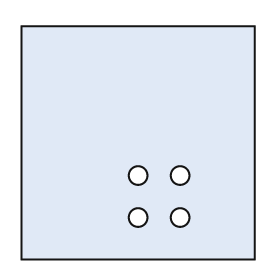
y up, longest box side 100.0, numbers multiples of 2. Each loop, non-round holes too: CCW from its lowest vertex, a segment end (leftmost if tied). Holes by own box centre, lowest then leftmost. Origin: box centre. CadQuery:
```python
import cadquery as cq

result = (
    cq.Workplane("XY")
    .moveTo(-50.0, -50.0)
    .lineTo(50.0, -50.0)
    .lineTo(50.0, 50.0)
    .lineTo(-50.0, 50.0)
    .close()
    .moveTo(0.0, -32.0)
    .circle(4.0)
    .moveTo(18.0, -32.0)
    .circle(4.0)
    .moveTo(0.0, -14.0)
    .circle(4.0)
    .moveTo(18.0, -14.0)
    .circle(4.0)
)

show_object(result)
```